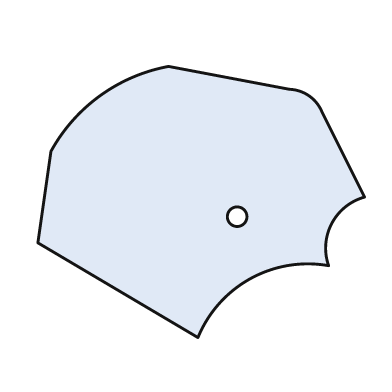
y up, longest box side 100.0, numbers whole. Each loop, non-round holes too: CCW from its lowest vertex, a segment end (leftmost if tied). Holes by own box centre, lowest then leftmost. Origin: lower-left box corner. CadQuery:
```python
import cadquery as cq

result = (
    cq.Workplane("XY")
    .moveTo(49.0, 0.0)
    .threePointArc((65.0, 18.0), (89.0, 22.0))
    .threePointArc((90.0, 35.0), (100.0, 43.0))
    .lineTo(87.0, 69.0)
    .threePointArc((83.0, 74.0), (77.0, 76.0))
    .lineTo(40.0, 83.0)
    .threePointArc((19.0, 74.0), (4.0, 57.0))
    .lineTo(0.0, 29.0)
    .close()
    .moveTo(61.0, 37.0)
    .circle(3.0)
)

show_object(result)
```